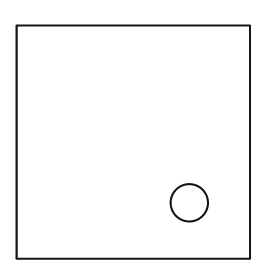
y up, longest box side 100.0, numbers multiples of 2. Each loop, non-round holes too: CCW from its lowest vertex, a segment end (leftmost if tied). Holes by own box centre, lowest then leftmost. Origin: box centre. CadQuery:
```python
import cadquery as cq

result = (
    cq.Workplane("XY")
    .moveTo(-50.0, -50.0)
    .lineTo(50.0, -50.0)
    .lineTo(50.0, 50.0)
    .lineTo(-50.0, 50.0)
    .close()
    .moveTo(24.0, -26.0)
    .circle(8.0)
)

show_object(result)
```